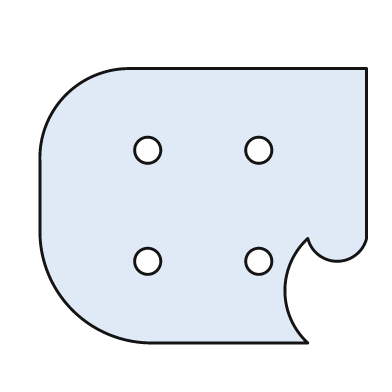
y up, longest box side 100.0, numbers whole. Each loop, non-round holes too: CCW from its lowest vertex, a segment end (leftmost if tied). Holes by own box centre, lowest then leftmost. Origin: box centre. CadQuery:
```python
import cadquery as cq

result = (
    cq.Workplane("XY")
    .moveTo(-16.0, -42.0)
    .lineTo(32.0, -42.0)
    .threePointArc((25.0, -26.0), (32.0, -10.0))
    .threePointArc((41.0, -17.0), (50.0, -10.0))
    .lineTo(50.0, 42.0)
    .lineTo(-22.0, 42.0)
    .threePointArc((-42.0, 34.0), (-50.0, 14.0))
    .lineTo(-50.0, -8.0)
    .threePointArc((-40.0, -32.0), (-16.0, -42.0))
    .close()
    .moveTo(-17.0, -17.0)
    .circle(4.0)
    .moveTo(17.0, -17.0)
    .circle(4.0)
    .moveTo(-17.0, 17.0)
    .circle(4.0)
    .moveTo(17.0, 17.0)
    .circle(4.0)
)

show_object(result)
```